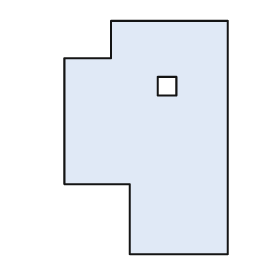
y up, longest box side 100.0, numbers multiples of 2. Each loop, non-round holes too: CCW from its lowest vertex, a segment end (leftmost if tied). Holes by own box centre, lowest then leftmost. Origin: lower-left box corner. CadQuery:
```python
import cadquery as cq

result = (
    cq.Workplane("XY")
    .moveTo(28.0, 0.0)
    .lineTo(70.0, 0.0)
    .lineTo(70.0, 100.0)
    .lineTo(20.0, 100.0)
    .lineTo(20.0, 84.0)
    .lineTo(0.0, 84.0)
    .lineTo(0.0, 30.0)
    .lineTo(28.0, 30.0)
    .close()
    .moveTo(40.0, 68.0)
    .lineTo(48.0, 68.0)
    .lineTo(48.0, 76.0)
    .lineTo(40.0, 76.0)
    .close()
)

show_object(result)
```